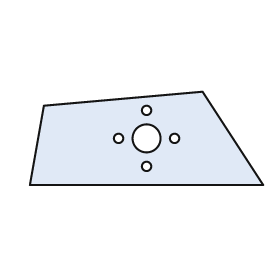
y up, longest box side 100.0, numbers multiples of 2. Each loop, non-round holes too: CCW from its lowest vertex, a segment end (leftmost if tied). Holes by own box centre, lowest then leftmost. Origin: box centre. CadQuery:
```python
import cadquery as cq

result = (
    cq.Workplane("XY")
    .moveTo(-50.0, -20.0)
    .lineTo(50.0, -20.0)
    .lineTo(24.0, 20.0)
    .lineTo(-44.0, 14.0)
    .close()
    .moveTo(0.0, -12.0)
    .circle(2.0)
    .moveTo(-12.0, 0.0)
    .circle(2.0)
    .moveTo(0.0, 0.0)
    .circle(6.0)
    .moveTo(12.0, 0.0)
    .circle(2.0)
    .moveTo(0.0, 12.0)
    .circle(2.0)
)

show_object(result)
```